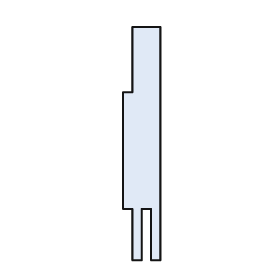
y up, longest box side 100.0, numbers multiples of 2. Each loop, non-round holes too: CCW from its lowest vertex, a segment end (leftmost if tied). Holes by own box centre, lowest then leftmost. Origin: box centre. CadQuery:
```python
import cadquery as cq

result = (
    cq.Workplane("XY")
    .moveTo(-4.0, -50.0)
    .lineTo(0.0, -50.0)
    .lineTo(0.0, -28.0)
    .lineTo(4.0, -28.0)
    .lineTo(4.0, -50.0)
    .lineTo(8.0, -50.0)
    .lineTo(8.0, 50.0)
    .lineTo(-4.0, 50.0)
    .lineTo(-4.0, 22.0)
    .lineTo(-8.0, 22.0)
    .lineTo(-8.0, -28.0)
    .lineTo(-4.0, -28.0)
    .close()
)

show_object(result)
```